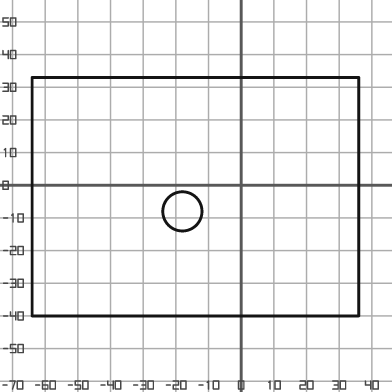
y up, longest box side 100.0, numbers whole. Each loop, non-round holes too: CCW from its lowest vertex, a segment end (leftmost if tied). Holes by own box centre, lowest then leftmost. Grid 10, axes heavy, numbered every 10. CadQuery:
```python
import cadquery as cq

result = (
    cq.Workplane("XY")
    .moveTo(-64.0, -40.0)
    .lineTo(36.0, -40.0)
    .lineTo(36.0, 33.0)
    .lineTo(-64.0, 33.0)
    .close()
    .moveTo(-18.0, -8.0)
    .circle(6.0)
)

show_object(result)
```